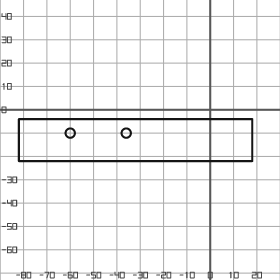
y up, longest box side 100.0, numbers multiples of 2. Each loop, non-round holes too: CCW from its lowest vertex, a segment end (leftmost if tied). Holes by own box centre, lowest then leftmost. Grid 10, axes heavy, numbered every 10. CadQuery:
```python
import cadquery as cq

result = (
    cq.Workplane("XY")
    .moveTo(-82.0, -22.0)
    .lineTo(18.0, -22.0)
    .lineTo(18.0, -4.0)
    .lineTo(-82.0, -4.0)
    .close()
    .moveTo(-60.0, -10.0)
    .circle(2.0)
    .moveTo(-36.0, -10.0)
    .circle(2.0)
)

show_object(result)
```